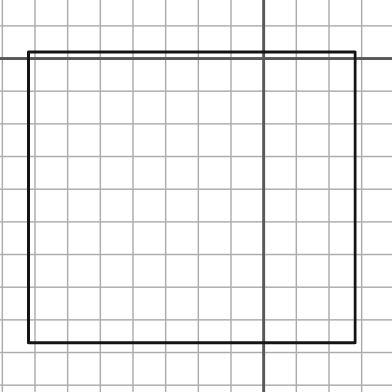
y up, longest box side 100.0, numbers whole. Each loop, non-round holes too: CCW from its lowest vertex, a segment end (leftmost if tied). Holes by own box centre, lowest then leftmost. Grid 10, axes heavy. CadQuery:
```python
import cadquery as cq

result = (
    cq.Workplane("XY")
    .moveTo(-72.0, -87.0)
    .lineTo(28.0, -87.0)
    .lineTo(28.0, 2.0)
    .lineTo(-72.0, 2.0)
    .close()
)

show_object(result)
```